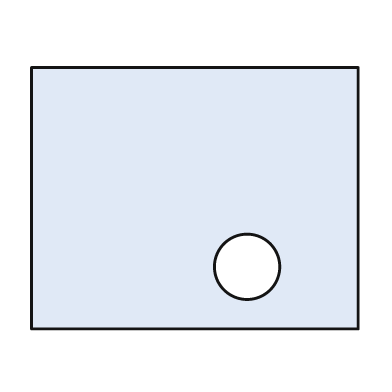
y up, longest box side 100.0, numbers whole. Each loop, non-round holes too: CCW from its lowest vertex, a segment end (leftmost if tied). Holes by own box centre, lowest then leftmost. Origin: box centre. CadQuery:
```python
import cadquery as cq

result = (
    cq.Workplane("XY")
    .moveTo(-50.0, -40.0)
    .lineTo(50.0, -40.0)
    .lineTo(50.0, 40.0)
    .lineTo(-50.0, 40.0)
    .close()
    .moveTo(16.0, -21.0)
    .circle(10.0)
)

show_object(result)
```